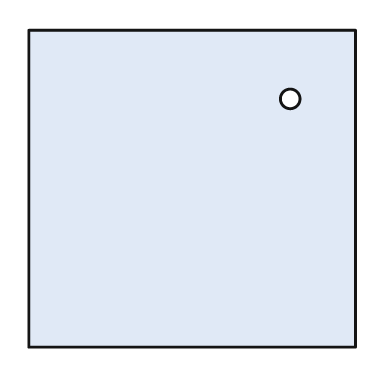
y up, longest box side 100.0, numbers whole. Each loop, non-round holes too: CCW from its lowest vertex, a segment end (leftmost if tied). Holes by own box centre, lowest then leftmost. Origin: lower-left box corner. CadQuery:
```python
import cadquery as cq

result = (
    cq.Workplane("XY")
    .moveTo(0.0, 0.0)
    .lineTo(100.0, 0.0)
    .lineTo(100.0, 97.0)
    .lineTo(0.0, 97.0)
    .close()
    .moveTo(80.0, 76.0)
    .circle(3.0)
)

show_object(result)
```